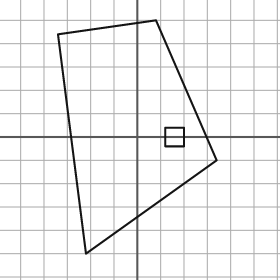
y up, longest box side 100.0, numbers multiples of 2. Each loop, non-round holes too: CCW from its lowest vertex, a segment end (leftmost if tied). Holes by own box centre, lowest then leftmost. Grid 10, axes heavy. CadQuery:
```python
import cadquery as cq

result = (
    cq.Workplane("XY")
    .moveTo(-22.0, -50.0)
    .lineTo(34.0, -10.0)
    .lineTo(8.0, 50.0)
    .lineTo(-34.0, 44.0)
    .close()
    .moveTo(12.0, -4.0)
    .lineTo(20.0, -4.0)
    .lineTo(20.0, 4.0)
    .lineTo(12.0, 4.0)
    .close()
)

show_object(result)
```